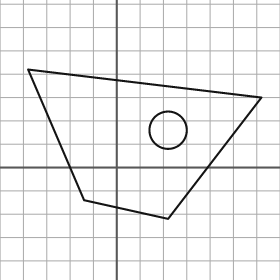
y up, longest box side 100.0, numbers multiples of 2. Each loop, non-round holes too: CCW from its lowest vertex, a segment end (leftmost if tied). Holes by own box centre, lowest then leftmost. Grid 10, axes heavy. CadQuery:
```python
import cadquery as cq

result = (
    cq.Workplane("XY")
    .moveTo(22.0, -22.0)
    .lineTo(62.0, 30.0)
    .lineTo(-38.0, 42.0)
    .lineTo(-14.0, -14.0)
    .close()
    .moveTo(22.0, 16.0)
    .circle(8.0)
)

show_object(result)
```